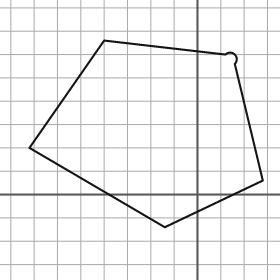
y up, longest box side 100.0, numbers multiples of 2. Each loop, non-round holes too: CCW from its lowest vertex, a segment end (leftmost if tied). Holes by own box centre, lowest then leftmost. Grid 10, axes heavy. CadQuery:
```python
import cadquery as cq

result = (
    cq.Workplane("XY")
    .moveTo(-14.0, -14.0)
    .lineTo(28.0, 6.0)
    .lineTo(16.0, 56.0)
    .threePointArc((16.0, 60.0), (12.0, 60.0))
    .lineTo(-40.0, 66.0)
    .lineTo(-72.0, 20.0)
    .close()
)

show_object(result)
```